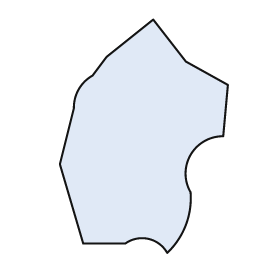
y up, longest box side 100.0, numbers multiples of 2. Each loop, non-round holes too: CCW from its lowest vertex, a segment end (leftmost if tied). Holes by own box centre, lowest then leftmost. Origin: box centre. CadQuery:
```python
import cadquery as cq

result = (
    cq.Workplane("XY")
    .moveTo(10.0, -50.0)
    .threePointArc((18.0, -38.0), (20.0, -24.0))
    .threePointArc((20.0, -8.0), (34.0, 0.0))
    .lineTo(36.0, 22.0)
    .lineTo(18.0, 32.0)
    .lineTo(4.0, 50.0)
    .lineTo(-16.0, 34.0)
    .lineTo(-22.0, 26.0)
    .threePointArc((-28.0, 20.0), (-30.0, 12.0))
    .lineTo(-36.0, -12.0)
    .lineTo(-26.0, -46.0)
    .lineTo(-8.0, -46.0)
    .threePointArc((2.0, -44.0), (10.0, -50.0))
    .close()
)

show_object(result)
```